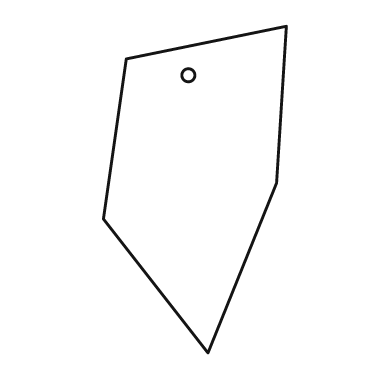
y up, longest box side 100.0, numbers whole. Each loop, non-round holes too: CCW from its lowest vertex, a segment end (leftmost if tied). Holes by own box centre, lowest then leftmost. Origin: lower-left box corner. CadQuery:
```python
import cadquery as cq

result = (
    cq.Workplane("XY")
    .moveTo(32.0, 0.0)
    .lineTo(53.0, 52.0)
    .lineTo(56.0, 100.0)
    .lineTo(7.0, 90.0)
    .lineTo(0.0, 41.0)
    .close()
    .moveTo(26.0, 85.0)
    .circle(2.0)
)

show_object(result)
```